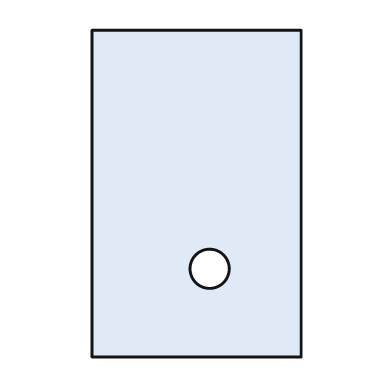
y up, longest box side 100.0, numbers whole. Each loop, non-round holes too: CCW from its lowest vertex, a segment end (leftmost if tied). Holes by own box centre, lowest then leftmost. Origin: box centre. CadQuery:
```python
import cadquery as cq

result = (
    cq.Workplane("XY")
    .moveTo(-32.0, -50.0)
    .lineTo(32.0, -50.0)
    .lineTo(32.0, 50.0)
    .lineTo(-32.0, 50.0)
    .close()
    .moveTo(4.0, -23.0)
    .circle(6.0)
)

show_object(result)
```